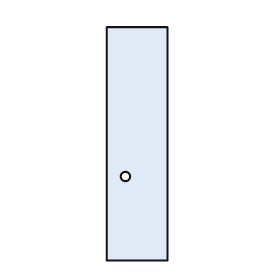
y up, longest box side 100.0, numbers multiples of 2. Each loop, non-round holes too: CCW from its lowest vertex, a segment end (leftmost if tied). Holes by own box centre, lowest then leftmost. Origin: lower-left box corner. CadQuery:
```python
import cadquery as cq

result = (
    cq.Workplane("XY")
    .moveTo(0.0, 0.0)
    .lineTo(26.0, 0.0)
    .lineTo(26.0, 100.0)
    .lineTo(0.0, 100.0)
    .close()
    .moveTo(8.0, 36.0)
    .circle(2.0)
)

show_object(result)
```